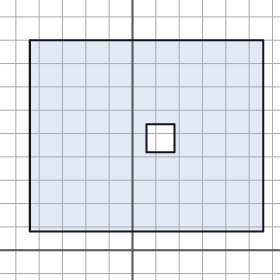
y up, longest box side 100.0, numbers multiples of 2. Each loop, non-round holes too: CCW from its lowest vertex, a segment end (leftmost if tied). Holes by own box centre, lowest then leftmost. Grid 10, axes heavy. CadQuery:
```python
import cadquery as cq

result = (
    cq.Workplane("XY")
    .moveTo(-44.0, 8.0)
    .lineTo(56.0, 8.0)
    .lineTo(56.0, 90.0)
    .lineTo(-44.0, 90.0)
    .close()
    .moveTo(6.0, 42.0)
    .lineTo(18.0, 42.0)
    .lineTo(18.0, 54.0)
    .lineTo(6.0, 54.0)
    .close()
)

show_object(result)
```